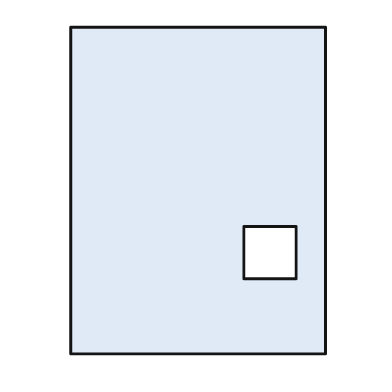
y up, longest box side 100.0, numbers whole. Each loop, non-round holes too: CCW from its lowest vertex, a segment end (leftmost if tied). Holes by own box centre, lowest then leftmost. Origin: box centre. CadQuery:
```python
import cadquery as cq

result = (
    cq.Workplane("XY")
    .moveTo(-39.0, -50.0)
    .lineTo(39.0, -50.0)
    .lineTo(39.0, 50.0)
    .lineTo(-39.0, 50.0)
    .close()
    .moveTo(14.0, -27.0)
    .lineTo(30.0, -27.0)
    .lineTo(30.0, -11.0)
    .lineTo(14.0, -11.0)
    .close()
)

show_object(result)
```